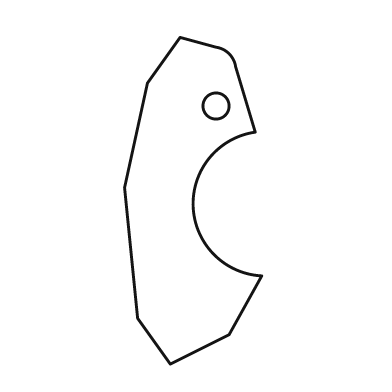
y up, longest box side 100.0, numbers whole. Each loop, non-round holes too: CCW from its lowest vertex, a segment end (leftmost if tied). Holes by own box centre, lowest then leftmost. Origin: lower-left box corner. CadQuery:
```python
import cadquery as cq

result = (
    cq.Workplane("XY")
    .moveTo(14.0, 0.0)
    .lineTo(32.0, 9.0)
    .lineTo(42.0, 27.0)
    .threePointArc((21.0, 48.0), (40.0, 71.0))
    .lineTo(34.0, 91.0)
    .threePointArc((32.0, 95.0), (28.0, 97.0))
    .lineTo(17.0, 100.0)
    .lineTo(7.0, 86.0)
    .lineTo(0.0, 54.0)
    .lineTo(4.0, 14.0)
    .close()
    .moveTo(28.0, 79.0)
    .circle(4.0)
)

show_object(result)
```